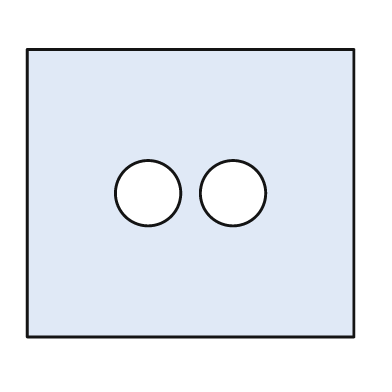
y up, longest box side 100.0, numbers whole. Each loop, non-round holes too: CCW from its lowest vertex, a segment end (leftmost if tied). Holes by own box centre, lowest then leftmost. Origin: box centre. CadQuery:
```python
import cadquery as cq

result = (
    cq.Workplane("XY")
    .moveTo(-50.0, -44.0)
    .lineTo(50.0, -44.0)
    .lineTo(50.0, 44.0)
    .lineTo(-50.0, 44.0)
    .close()
    .moveTo(-13.0, 0.0)
    .circle(10.0)
    .moveTo(13.0, 0.0)
    .circle(10.0)
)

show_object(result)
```